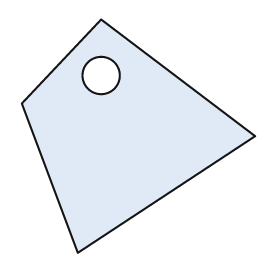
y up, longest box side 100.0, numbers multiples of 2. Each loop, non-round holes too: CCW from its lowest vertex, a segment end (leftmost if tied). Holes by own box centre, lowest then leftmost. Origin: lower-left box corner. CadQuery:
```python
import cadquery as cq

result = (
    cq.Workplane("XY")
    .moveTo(24.0, 0.0)
    .lineTo(100.0, 50.0)
    .lineTo(34.0, 100.0)
    .lineTo(0.0, 64.0)
    .close()
    .moveTo(34.0, 76.0)
    .circle(8.0)
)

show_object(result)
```